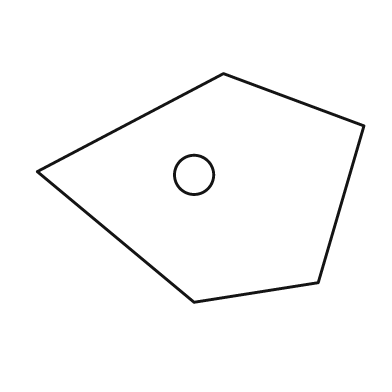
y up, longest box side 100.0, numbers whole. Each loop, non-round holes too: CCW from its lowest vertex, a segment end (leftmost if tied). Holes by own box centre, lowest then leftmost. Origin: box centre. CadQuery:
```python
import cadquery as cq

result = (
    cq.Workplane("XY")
    .moveTo(-2.0, -35.0)
    .lineTo(36.0, -29.0)
    .lineTo(50.0, 19.0)
    .lineTo(7.0, 35.0)
    .lineTo(-50.0, 5.0)
    .close()
    .moveTo(-2.0, 4.0)
    .circle(6.0)
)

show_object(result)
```